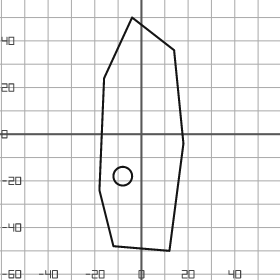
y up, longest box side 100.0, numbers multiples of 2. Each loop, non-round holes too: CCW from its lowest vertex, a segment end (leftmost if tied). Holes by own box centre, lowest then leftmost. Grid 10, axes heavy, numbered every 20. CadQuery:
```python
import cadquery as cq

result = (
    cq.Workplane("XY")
    .moveTo(12.0, -50.0)
    .lineTo(18.0, -4.0)
    .lineTo(14.0, 36.0)
    .lineTo(-4.0, 50.0)
    .lineTo(-16.0, 24.0)
    .lineTo(-18.0, -24.0)
    .lineTo(-12.0, -48.0)
    .close()
    .moveTo(-8.0, -18.0)
    .circle(4.0)
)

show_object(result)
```